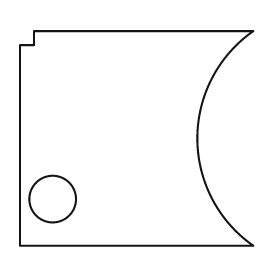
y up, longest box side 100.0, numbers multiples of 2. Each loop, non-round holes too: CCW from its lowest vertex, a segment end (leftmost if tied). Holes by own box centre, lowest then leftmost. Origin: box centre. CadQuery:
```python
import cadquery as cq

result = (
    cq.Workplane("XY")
    .moveTo(-50.0, -46.0)
    .lineTo(50.0, -46.0)
    .threePointArc((26.0, 0.0), (50.0, 46.0))
    .lineTo(-44.0, 46.0)
    .lineTo(-44.0, 40.0)
    .lineTo(-50.0, 40.0)
    .close()
    .moveTo(-36.0, -26.0)
    .circle(10.0)
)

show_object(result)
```